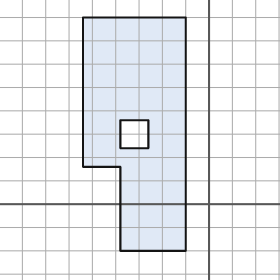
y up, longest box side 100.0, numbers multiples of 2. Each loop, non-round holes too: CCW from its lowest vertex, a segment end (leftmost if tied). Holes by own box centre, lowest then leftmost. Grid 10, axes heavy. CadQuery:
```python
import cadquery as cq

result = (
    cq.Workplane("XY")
    .moveTo(-38.0, -20.0)
    .lineTo(-10.0, -20.0)
    .lineTo(-10.0, 80.0)
    .lineTo(-54.0, 80.0)
    .lineTo(-54.0, 16.0)
    .lineTo(-38.0, 16.0)
    .close()
    .moveTo(-38.0, 24.0)
    .lineTo(-26.0, 24.0)
    .lineTo(-26.0, 36.0)
    .lineTo(-38.0, 36.0)
    .close()
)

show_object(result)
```